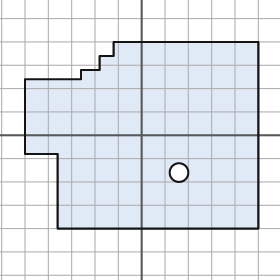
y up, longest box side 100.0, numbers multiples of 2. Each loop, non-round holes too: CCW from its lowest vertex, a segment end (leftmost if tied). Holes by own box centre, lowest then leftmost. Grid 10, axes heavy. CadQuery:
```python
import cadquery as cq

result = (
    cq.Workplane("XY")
    .moveTo(-36.0, -40.0)
    .lineTo(50.0, -40.0)
    .lineTo(50.0, 40.0)
    .lineTo(-12.0, 40.0)
    .lineTo(-12.0, 34.0)
    .lineTo(-18.0, 34.0)
    .lineTo(-18.0, 28.0)
    .lineTo(-26.0, 28.0)
    .lineTo(-26.0, 24.0)
    .lineTo(-50.0, 24.0)
    .lineTo(-50.0, -8.0)
    .lineTo(-36.0, -8.0)
    .close()
    .moveTo(16.0, -16.0)
    .circle(4.0)
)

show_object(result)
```